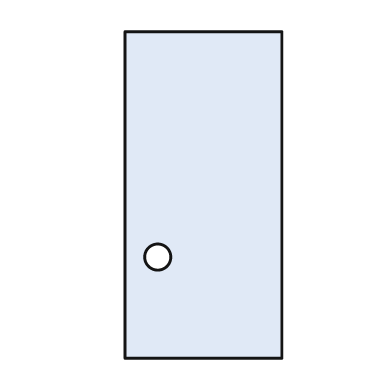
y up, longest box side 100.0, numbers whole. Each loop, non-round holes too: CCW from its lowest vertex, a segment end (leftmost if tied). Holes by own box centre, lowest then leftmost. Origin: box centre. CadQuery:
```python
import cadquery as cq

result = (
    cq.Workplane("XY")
    .moveTo(-24.0, -50.0)
    .lineTo(24.0, -50.0)
    .lineTo(24.0, 50.0)
    .lineTo(-24.0, 50.0)
    .close()
    .moveTo(-14.0, -19.0)
    .circle(4.0)
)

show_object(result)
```